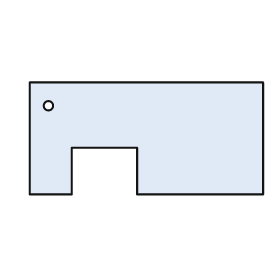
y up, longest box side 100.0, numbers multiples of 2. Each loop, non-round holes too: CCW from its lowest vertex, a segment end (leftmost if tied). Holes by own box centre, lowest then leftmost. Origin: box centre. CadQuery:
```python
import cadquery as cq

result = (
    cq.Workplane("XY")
    .moveTo(-50.0, -24.0)
    .lineTo(-32.0, -24.0)
    .lineTo(-32.0, -4.0)
    .lineTo(-4.0, -4.0)
    .lineTo(-4.0, -24.0)
    .lineTo(50.0, -24.0)
    .lineTo(50.0, 24.0)
    .lineTo(-50.0, 24.0)
    .close()
    .moveTo(-42.0, 14.0)
    .circle(2.0)
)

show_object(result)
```